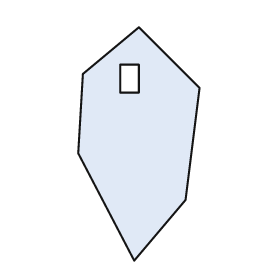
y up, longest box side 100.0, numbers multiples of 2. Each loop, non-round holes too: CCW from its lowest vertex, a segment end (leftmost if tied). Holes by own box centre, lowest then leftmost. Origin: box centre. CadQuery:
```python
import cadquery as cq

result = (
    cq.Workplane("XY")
    .moveTo(-2.0, -50.0)
    .lineTo(20.0, -24.0)
    .lineTo(26.0, 24.0)
    .lineTo(0.0, 50.0)
    .lineTo(-24.0, 30.0)
    .lineTo(-26.0, -4.0)
    .close()
    .moveTo(-8.0, 22.0)
    .lineTo(0.0, 22.0)
    .lineTo(0.0, 34.0)
    .lineTo(-8.0, 34.0)
    .close()
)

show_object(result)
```